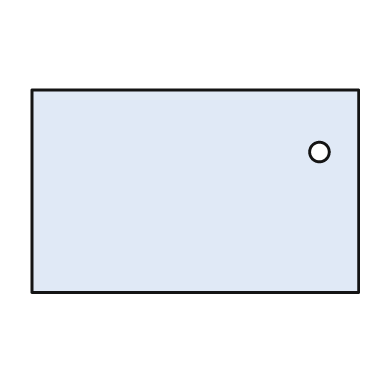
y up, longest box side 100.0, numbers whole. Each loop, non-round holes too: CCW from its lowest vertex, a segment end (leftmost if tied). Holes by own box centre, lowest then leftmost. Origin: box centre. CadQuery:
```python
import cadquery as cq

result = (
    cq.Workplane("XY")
    .moveTo(-50.0, -31.0)
    .lineTo(50.0, -31.0)
    .lineTo(50.0, 31.0)
    .lineTo(-50.0, 31.0)
    .close()
    .moveTo(38.0, 12.0)
    .circle(3.0)
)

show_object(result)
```